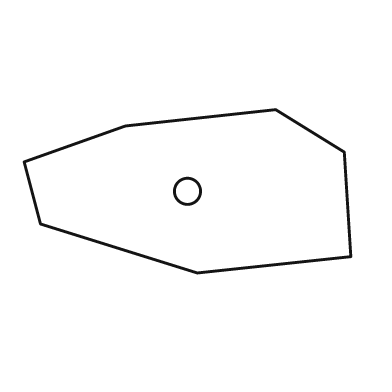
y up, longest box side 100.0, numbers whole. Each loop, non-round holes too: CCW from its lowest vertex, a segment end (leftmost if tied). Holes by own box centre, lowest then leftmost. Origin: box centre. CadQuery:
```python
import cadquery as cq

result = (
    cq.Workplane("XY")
    .moveTo(3.0, -25.0)
    .lineTo(50.0, -20.0)
    .lineTo(48.0, 12.0)
    .lineTo(27.0, 25.0)
    .lineTo(-19.0, 20.0)
    .lineTo(-50.0, 9.0)
    .lineTo(-45.0, -10.0)
    .close()
    .moveTo(0.0, 0.0)
    .circle(4.0)
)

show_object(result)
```